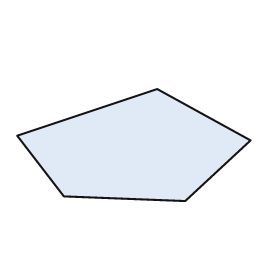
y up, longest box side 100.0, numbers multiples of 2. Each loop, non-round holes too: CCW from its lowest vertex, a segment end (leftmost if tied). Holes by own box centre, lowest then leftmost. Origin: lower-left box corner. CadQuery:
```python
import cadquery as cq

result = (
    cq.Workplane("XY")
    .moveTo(72.0, 0.0)
    .lineTo(100.0, 26.0)
    .lineTo(60.0, 48.0)
    .lineTo(0.0, 28.0)
    .lineTo(20.0, 2.0)
    .close()
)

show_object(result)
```